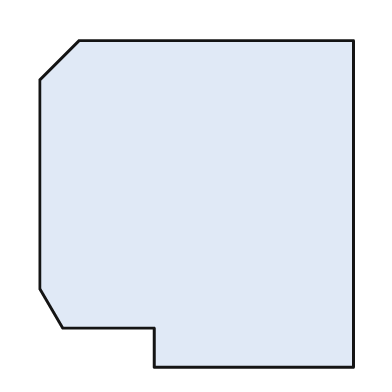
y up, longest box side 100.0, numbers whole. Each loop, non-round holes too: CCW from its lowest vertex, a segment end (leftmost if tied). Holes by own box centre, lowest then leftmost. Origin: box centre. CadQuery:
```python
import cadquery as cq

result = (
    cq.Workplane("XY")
    .moveTo(-13.0, -50.0)
    .lineTo(48.0, -50.0)
    .lineTo(48.0, 50.0)
    .lineTo(-36.0, 50.0)
    .lineTo(-48.0, 38.0)
    .lineTo(-48.0, -26.0)
    .lineTo(-41.0, -38.0)
    .lineTo(-13.0, -38.0)
    .close()
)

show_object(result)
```